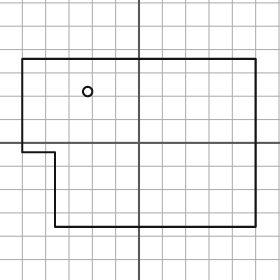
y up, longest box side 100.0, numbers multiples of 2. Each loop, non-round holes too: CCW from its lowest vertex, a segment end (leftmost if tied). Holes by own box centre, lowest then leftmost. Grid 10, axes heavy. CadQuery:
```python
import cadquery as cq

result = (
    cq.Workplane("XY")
    .moveTo(-36.0, -36.0)
    .lineTo(50.0, -36.0)
    .lineTo(50.0, 36.0)
    .lineTo(-50.0, 36.0)
    .lineTo(-50.0, -4.0)
    .lineTo(-36.0, -4.0)
    .close()
    .moveTo(-22.0, 22.0)
    .circle(2.0)
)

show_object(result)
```